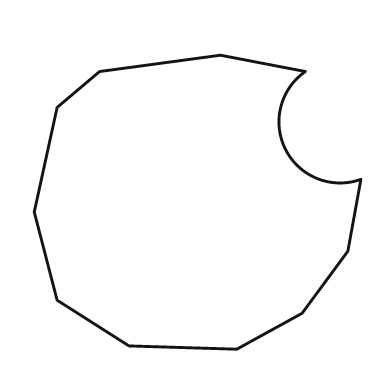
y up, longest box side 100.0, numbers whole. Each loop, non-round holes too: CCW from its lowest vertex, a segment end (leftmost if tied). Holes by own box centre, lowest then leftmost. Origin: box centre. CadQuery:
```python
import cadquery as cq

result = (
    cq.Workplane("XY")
    .moveTo(12.0, -45.0)
    .lineTo(32.0, -34.0)
    .lineTo(46.0, -15.0)
    .lineTo(50.0, 7.0)
    .threePointArc((27.0, 16.0), (33.0, 40.0))
    .lineTo(7.0, 45.0)
    .lineTo(-30.0, 40.0)
    .lineTo(-43.0, 29.0)
    .lineTo(-50.0, -3.0)
    .lineTo(-43.0, -30.0)
    .lineTo(-21.0, -44.0)
    .close()
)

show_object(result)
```